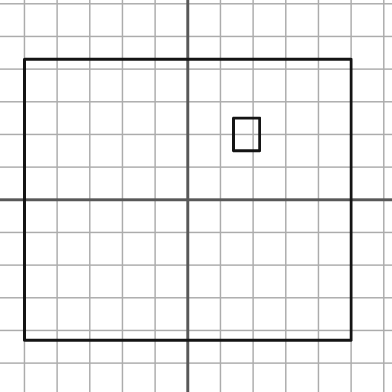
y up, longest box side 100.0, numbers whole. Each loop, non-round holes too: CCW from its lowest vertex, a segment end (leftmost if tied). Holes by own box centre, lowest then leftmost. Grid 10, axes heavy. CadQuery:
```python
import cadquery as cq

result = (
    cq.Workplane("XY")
    .moveTo(-50.0, -43.0)
    .lineTo(50.0, -43.0)
    .lineTo(50.0, 43.0)
    .lineTo(-50.0, 43.0)
    .close()
    .moveTo(14.0, 15.0)
    .lineTo(22.0, 15.0)
    .lineTo(22.0, 25.0)
    .lineTo(14.0, 25.0)
    .close()
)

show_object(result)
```